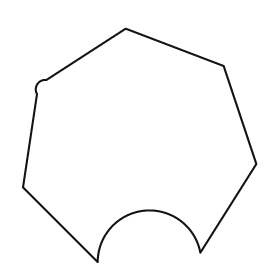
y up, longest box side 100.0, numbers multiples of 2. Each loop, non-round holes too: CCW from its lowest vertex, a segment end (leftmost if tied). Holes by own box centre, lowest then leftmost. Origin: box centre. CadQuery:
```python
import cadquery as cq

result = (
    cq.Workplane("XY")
    .moveTo(-18.0, -50.0)
    .threePointArc((2.0, -28.0), (26.0, -46.0))
    .lineTo(50.0, -8.0)
    .lineTo(36.0, 34.0)
    .lineTo(-6.0, 50.0)
    .lineTo(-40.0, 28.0)
    .threePointArc((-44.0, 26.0), (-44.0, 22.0))
    .lineTo(-50.0, -18.0)
    .close()
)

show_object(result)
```